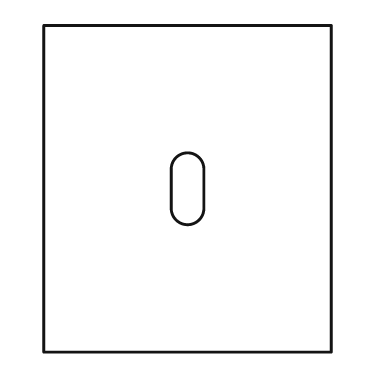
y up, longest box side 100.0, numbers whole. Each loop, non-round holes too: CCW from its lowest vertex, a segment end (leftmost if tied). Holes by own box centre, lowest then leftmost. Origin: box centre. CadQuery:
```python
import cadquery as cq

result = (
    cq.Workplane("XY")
    .moveTo(-44.0, -50.0)
    .lineTo(44.0, -50.0)
    .lineTo(44.0, 50.0)
    .lineTo(-44.0, 50.0)
    .close()
    .moveTo(-5.0, -6.0)
    .threePointArc((0.0, -11.0), (5.0, -6.0))
    .lineTo(5.0, 6.0)
    .threePointArc((0.0, 11.0), (-5.0, 6.0))
    .close()
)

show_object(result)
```